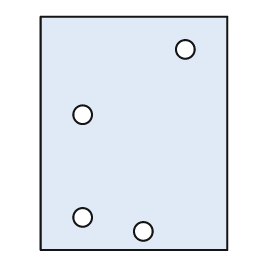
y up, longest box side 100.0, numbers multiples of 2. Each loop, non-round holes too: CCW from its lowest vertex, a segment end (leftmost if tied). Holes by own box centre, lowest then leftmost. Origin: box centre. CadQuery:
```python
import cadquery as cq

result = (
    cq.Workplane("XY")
    .moveTo(-40.0, -50.0)
    .lineTo(40.0, -50.0)
    .lineTo(40.0, 50.0)
    .lineTo(-40.0, 50.0)
    .close()
    .moveTo(4.0, -42.0)
    .circle(4.0)
    .moveTo(-22.0, -36.0)
    .circle(4.0)
    .moveTo(-22.0, 8.0)
    .circle(4.0)
    .moveTo(22.0, 36.0)
    .circle(4.0)
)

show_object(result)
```